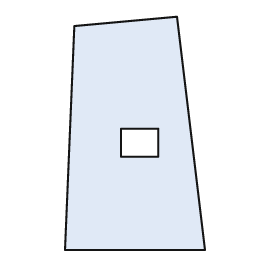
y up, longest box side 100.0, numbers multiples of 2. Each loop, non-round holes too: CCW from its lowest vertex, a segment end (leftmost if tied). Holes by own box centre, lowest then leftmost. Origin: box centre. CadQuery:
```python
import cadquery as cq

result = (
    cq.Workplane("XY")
    .moveTo(-30.0, -50.0)
    .lineTo(30.0, -50.0)
    .lineTo(18.0, 50.0)
    .lineTo(-26.0, 46.0)
    .close()
    .moveTo(-6.0, -10.0)
    .lineTo(10.0, -10.0)
    .lineTo(10.0, 2.0)
    .lineTo(-6.0, 2.0)
    .close()
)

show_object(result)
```